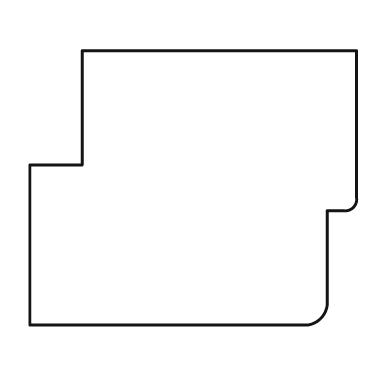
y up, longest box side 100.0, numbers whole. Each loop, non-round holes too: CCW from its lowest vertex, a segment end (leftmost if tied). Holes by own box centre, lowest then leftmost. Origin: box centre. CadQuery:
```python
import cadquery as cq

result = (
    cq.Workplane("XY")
    .moveTo(-50.0, -42.0)
    .lineTo(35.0, -42.0)
    .threePointArc((39.0, -40.0), (41.0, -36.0))
    .lineTo(41.0, -7.0)
    .lineTo(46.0, -7.0)
    .threePointArc((49.0, -6.0), (50.0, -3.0))
    .lineTo(50.0, 42.0)
    .lineTo(-34.0, 42.0)
    .lineTo(-34.0, 7.0)
    .lineTo(-50.0, 7.0)
    .close()
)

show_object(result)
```